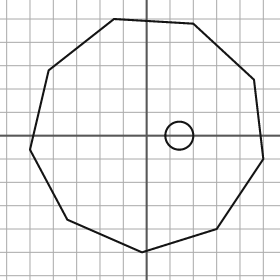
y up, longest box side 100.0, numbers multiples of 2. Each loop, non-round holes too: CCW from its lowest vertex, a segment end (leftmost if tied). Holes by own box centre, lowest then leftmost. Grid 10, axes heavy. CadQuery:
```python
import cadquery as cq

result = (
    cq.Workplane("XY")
    .moveTo(-2.0, -50.0)
    .lineTo(30.0, -40.0)
    .lineTo(50.0, -10.0)
    .lineTo(46.0, 24.0)
    .lineTo(20.0, 48.0)
    .lineTo(-14.0, 50.0)
    .lineTo(-42.0, 28.0)
    .lineTo(-50.0, -6.0)
    .lineTo(-34.0, -36.0)
    .close()
    .moveTo(14.0, 0.0)
    .circle(6.0)
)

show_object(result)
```